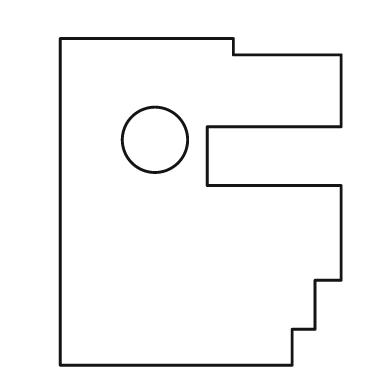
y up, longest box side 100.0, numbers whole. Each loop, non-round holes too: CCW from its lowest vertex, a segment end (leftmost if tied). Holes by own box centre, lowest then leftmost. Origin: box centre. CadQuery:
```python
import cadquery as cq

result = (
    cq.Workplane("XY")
    .moveTo(-43.0, -50.0)
    .lineTo(28.0, -50.0)
    .lineTo(28.0, -39.0)
    .lineTo(35.0, -39.0)
    .lineTo(35.0, -24.0)
    .lineTo(43.0, -24.0)
    .lineTo(43.0, 5.0)
    .lineTo(2.0, 5.0)
    .lineTo(2.0, 23.0)
    .lineTo(43.0, 23.0)
    .lineTo(43.0, 45.0)
    .lineTo(10.0, 45.0)
    .lineTo(10.0, 50.0)
    .lineTo(-43.0, 50.0)
    .close()
    .moveTo(-14.0, 19.0)
    .circle(10.0)
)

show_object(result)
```